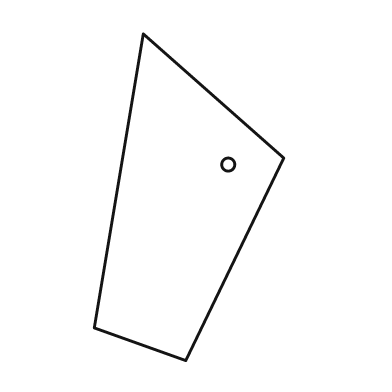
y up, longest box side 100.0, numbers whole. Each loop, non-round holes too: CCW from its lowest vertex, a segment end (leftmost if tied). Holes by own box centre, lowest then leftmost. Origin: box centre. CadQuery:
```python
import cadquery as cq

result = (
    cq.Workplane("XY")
    .moveTo(-1.0, -50.0)
    .lineTo(29.0, 12.0)
    .lineTo(-14.0, 50.0)
    .lineTo(-29.0, -40.0)
    .close()
    .moveTo(12.0, 10.0)
    .circle(2.0)
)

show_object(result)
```